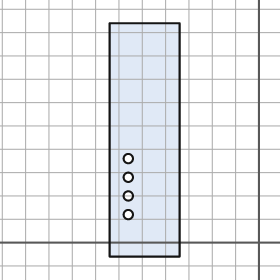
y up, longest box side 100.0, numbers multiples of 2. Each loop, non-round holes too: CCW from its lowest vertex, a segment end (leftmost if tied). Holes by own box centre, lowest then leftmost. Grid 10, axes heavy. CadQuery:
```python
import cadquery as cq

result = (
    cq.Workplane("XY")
    .moveTo(-64.0, -6.0)
    .lineTo(-34.0, -6.0)
    .lineTo(-34.0, 94.0)
    .lineTo(-64.0, 94.0)
    .close()
    .moveTo(-56.0, 12.0)
    .circle(2.0)
    .moveTo(-56.0, 20.0)
    .circle(2.0)
    .moveTo(-56.0, 28.0)
    .circle(2.0)
    .moveTo(-56.0, 36.0)
    .circle(2.0)
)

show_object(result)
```